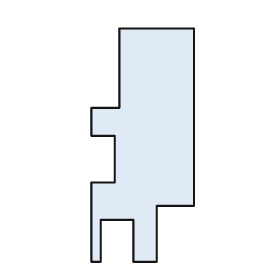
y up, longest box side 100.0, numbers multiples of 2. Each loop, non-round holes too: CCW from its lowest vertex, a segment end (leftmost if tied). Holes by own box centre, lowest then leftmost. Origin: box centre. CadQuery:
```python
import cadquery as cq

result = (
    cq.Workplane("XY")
    .moveTo(-22.0, -50.0)
    .lineTo(-18.0, -50.0)
    .lineTo(-18.0, -32.0)
    .lineTo(-4.0, -32.0)
    .lineTo(-4.0, -50.0)
    .lineTo(6.0, -50.0)
    .lineTo(6.0, -26.0)
    .lineTo(22.0, -26.0)
    .lineTo(22.0, 50.0)
    .lineTo(-10.0, 50.0)
    .lineTo(-10.0, 16.0)
    .lineTo(-22.0, 16.0)
    .lineTo(-22.0, 4.0)
    .lineTo(-12.0, 4.0)
    .lineTo(-12.0, -16.0)
    .lineTo(-22.0, -16.0)
    .close()
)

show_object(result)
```